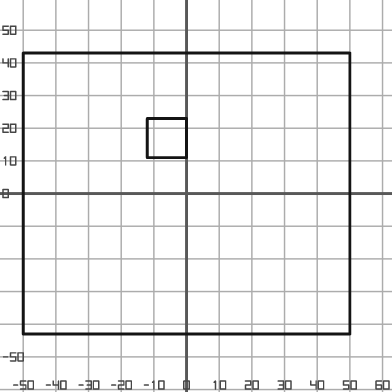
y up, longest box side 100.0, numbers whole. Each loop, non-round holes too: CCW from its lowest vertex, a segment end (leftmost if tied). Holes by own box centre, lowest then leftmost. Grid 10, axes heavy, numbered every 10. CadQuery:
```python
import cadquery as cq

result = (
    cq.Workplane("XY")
    .moveTo(-50.0, -43.0)
    .lineTo(50.0, -43.0)
    .lineTo(50.0, 43.0)
    .lineTo(-50.0, 43.0)
    .close()
    .moveTo(-12.0, 11.0)
    .lineTo(0.0, 11.0)
    .lineTo(0.0, 23.0)
    .lineTo(-12.0, 23.0)
    .close()
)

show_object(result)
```